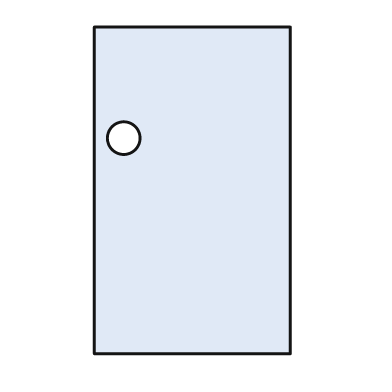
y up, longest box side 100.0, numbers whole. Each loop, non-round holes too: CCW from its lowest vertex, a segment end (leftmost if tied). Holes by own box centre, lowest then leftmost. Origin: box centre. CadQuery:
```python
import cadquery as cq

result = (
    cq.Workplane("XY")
    .moveTo(-30.0, -50.0)
    .lineTo(30.0, -50.0)
    .lineTo(30.0, 50.0)
    .lineTo(-30.0, 50.0)
    .close()
    .moveTo(-21.0, 16.0)
    .circle(5.0)
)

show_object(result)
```